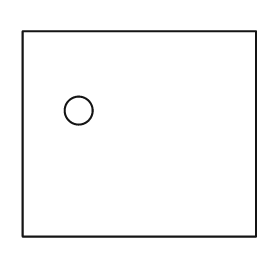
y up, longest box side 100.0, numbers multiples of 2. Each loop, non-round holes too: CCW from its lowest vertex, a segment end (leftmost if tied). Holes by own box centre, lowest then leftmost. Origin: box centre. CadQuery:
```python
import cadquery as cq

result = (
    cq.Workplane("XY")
    .moveTo(-50.0, -44.0)
    .lineTo(50.0, -44.0)
    .lineTo(50.0, 44.0)
    .lineTo(-50.0, 44.0)
    .close()
    .moveTo(-26.0, 10.0)
    .circle(6.0)
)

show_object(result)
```